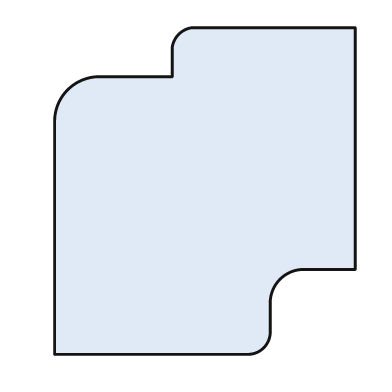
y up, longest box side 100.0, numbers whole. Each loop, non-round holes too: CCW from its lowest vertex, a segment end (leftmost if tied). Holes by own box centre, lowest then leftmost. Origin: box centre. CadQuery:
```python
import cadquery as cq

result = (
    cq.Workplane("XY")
    .moveTo(-46.0, -50.0)
    .lineTo(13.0, -50.0)
    .threePointArc((18.0, -48.0), (20.0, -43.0))
    .lineTo(20.0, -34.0)
    .threePointArc((23.0, -27.0), (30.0, -24.0))
    .lineTo(46.0, -24.0)
    .lineTo(46.0, 50.0)
    .lineTo(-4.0, 50.0)
    .threePointArc((-8.0, 48.0), (-10.0, 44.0))
    .lineTo(-10.0, 35.0)
    .lineTo(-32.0, 35.0)
    .threePointArc((-42.0, 31.0), (-46.0, 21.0))
    .close()
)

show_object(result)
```